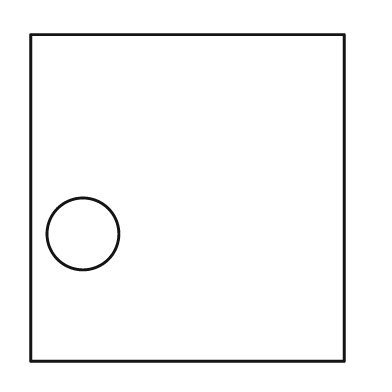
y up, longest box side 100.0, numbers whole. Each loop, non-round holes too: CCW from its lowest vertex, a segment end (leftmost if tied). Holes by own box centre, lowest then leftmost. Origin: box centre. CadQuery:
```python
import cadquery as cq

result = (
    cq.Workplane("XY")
    .moveTo(-48.0, -50.0)
    .lineTo(48.0, -50.0)
    .lineTo(48.0, 50.0)
    .lineTo(-48.0, 50.0)
    .close()
    .moveTo(-32.0, -11.0)
    .circle(11.0)
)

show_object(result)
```